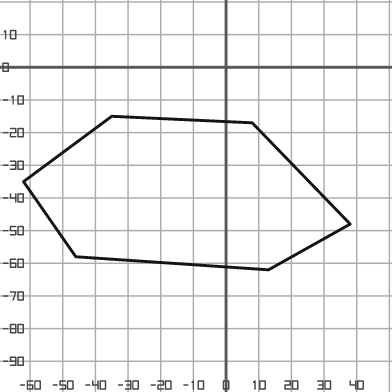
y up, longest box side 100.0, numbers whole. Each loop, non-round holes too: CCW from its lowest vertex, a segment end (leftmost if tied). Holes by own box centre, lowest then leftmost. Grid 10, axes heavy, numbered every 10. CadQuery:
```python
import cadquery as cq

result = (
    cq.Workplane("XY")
    .moveTo(13.0, -62.0)
    .lineTo(38.0, -48.0)
    .lineTo(8.0, -17.0)
    .lineTo(-35.0, -15.0)
    .lineTo(-62.0, -35.0)
    .lineTo(-46.0, -58.0)
    .close()
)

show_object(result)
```